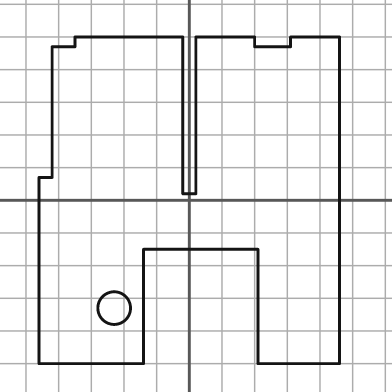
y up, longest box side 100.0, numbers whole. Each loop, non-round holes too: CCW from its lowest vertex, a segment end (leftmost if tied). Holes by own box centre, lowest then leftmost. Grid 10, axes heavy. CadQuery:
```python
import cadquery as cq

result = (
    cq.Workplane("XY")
    .moveTo(-46.0, -50.0)
    .lineTo(-14.0, -50.0)
    .lineTo(-14.0, -15.0)
    .lineTo(21.0, -15.0)
    .lineTo(21.0, -50.0)
    .lineTo(46.0, -50.0)
    .lineTo(46.0, 50.0)
    .lineTo(31.0, 50.0)
    .lineTo(31.0, 47.0)
    .lineTo(20.0, 47.0)
    .lineTo(20.0, 50.0)
    .lineTo(2.0, 50.0)
    .lineTo(2.0, 2.0)
    .lineTo(-2.0, 2.0)
    .lineTo(-2.0, 50.0)
    .lineTo(-35.0, 50.0)
    .lineTo(-35.0, 47.0)
    .lineTo(-42.0, 47.0)
    .lineTo(-42.0, 7.0)
    .lineTo(-46.0, 7.0)
    .close()
    .moveTo(-23.0, -33.0)
    .circle(5.0)
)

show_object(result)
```